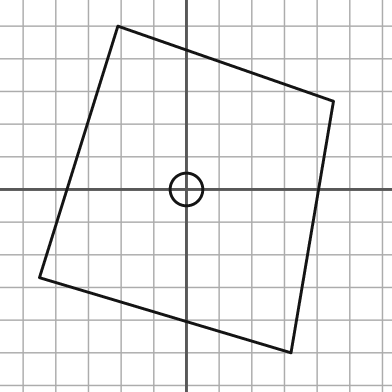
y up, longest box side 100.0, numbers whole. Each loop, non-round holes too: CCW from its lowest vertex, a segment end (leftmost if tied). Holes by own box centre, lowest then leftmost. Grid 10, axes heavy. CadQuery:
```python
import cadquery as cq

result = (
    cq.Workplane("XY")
    .moveTo(32.0, -50.0)
    .lineTo(45.0, 27.0)
    .lineTo(-21.0, 50.0)
    .lineTo(-45.0, -27.0)
    .close()
    .moveTo(0.0, 0.0)
    .circle(5.0)
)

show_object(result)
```